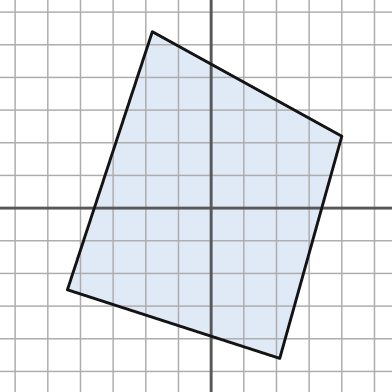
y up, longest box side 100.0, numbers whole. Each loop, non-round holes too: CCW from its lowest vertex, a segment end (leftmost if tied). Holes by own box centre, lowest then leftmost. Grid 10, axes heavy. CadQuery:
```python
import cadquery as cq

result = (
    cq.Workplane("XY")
    .moveTo(21.0, -46.0)
    .lineTo(40.0, 22.0)
    .lineTo(-18.0, 54.0)
    .lineTo(-44.0, -25.0)
    .close()
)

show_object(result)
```